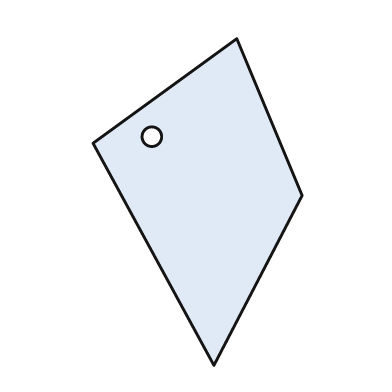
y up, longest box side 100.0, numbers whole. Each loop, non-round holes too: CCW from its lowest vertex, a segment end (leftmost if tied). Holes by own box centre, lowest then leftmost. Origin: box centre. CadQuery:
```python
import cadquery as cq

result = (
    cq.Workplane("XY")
    .moveTo(5.0, -50.0)
    .lineTo(32.0, 2.0)
    .lineTo(12.0, 50.0)
    .lineTo(-32.0, 18.0)
    .close()
    .moveTo(-14.0, 20.0)
    .circle(3.0)
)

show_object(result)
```